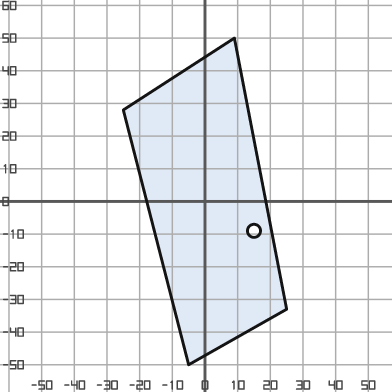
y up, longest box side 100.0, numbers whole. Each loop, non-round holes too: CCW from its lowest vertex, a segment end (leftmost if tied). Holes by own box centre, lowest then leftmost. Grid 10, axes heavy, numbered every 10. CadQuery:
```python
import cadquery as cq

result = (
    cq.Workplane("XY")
    .moveTo(-5.0, -50.0)
    .lineTo(25.0, -33.0)
    .lineTo(9.0, 50.0)
    .lineTo(-25.0, 28.0)
    .close()
    .moveTo(15.0, -9.0)
    .circle(2.0)
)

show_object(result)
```